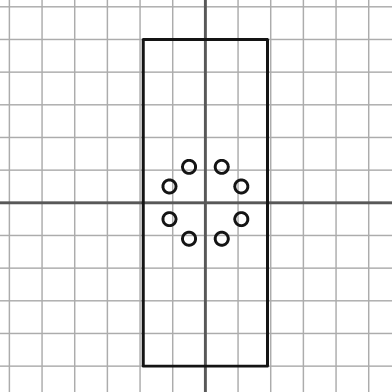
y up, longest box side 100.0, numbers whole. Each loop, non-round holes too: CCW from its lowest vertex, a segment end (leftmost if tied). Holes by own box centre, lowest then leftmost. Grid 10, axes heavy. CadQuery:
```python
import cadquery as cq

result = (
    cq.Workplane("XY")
    .moveTo(-19.0, -50.0)
    .lineTo(19.0, -50.0)
    .lineTo(19.0, 50.0)
    .lineTo(-19.0, 50.0)
    .close()
    .moveTo(-5.0, -11.0)
    .circle(2.0)
    .moveTo(5.0, -11.0)
    .circle(2.0)
    .moveTo(-11.0, -5.0)
    .circle(2.0)
    .moveTo(11.0, -5.0)
    .circle(2.0)
    .moveTo(-11.0, 5.0)
    .circle(2.0)
    .moveTo(11.0, 5.0)
    .circle(2.0)
    .moveTo(-5.0, 11.0)
    .circle(2.0)
    .moveTo(5.0, 11.0)
    .circle(2.0)
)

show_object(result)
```